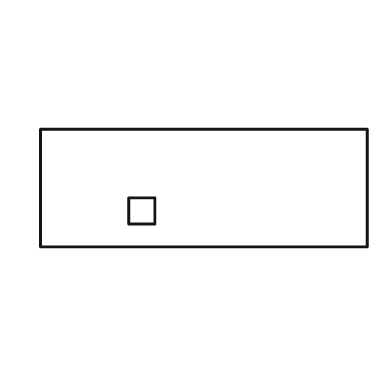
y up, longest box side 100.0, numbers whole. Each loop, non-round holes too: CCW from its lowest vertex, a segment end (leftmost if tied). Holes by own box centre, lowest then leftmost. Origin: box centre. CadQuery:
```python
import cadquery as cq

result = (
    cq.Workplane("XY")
    .moveTo(-50.0, -18.0)
    .lineTo(50.0, -18.0)
    .lineTo(50.0, 18.0)
    .lineTo(-50.0, 18.0)
    .close()
    .moveTo(-23.0, -11.0)
    .lineTo(-15.0, -11.0)
    .lineTo(-15.0, -3.0)
    .lineTo(-23.0, -3.0)
    .close()
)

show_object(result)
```